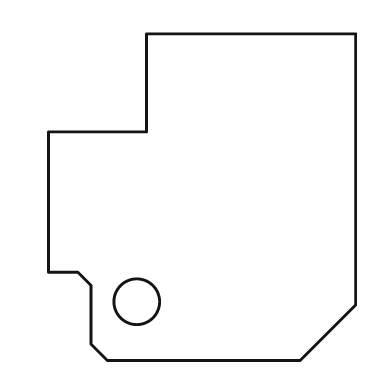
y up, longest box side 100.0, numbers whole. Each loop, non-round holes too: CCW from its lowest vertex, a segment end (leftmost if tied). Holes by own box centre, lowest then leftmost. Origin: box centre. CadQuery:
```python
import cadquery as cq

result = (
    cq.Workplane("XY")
    .moveTo(-29.0, -50.0)
    .lineTo(30.0, -50.0)
    .lineTo(47.0, -33.0)
    .lineTo(47.0, 50.0)
    .lineTo(-17.0, 50.0)
    .lineTo(-17.0, 20.0)
    .lineTo(-47.0, 20.0)
    .lineTo(-47.0, -23.0)
    .lineTo(-38.0, -23.0)
    .lineTo(-34.0, -27.0)
    .lineTo(-34.0, -45.0)
    .close()
    .moveTo(-20.0, -32.0)
    .circle(7.0)
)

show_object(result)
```